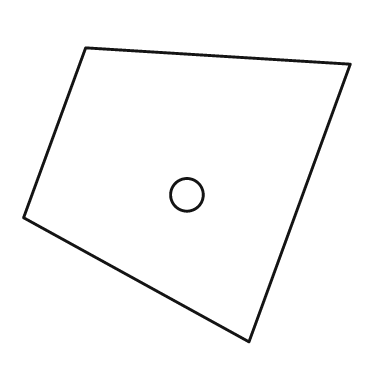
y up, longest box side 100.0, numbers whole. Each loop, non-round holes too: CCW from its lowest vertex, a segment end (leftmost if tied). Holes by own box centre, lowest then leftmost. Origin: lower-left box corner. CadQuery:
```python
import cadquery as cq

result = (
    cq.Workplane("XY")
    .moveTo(69.0, 0.0)
    .lineTo(100.0, 85.0)
    .lineTo(19.0, 90.0)
    .lineTo(0.0, 38.0)
    .close()
    .moveTo(50.0, 45.0)
    .circle(5.0)
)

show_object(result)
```